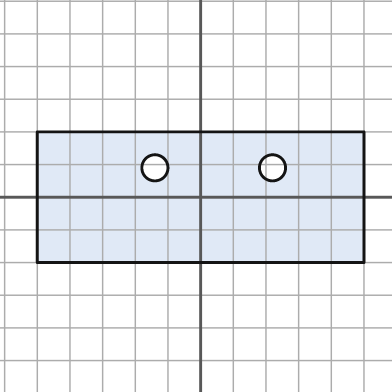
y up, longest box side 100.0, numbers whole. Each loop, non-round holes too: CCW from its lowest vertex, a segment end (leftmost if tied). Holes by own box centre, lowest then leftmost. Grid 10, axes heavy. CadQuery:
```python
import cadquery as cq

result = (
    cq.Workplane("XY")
    .moveTo(-50.0, -20.0)
    .lineTo(50.0, -20.0)
    .lineTo(50.0, 20.0)
    .lineTo(-50.0, 20.0)
    .close()
    .moveTo(-14.0, 9.0)
    .circle(4.0)
    .moveTo(22.0, 9.0)
    .circle(4.0)
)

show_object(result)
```